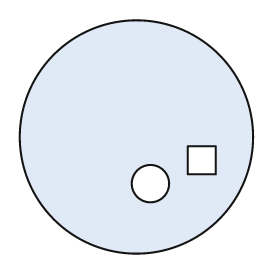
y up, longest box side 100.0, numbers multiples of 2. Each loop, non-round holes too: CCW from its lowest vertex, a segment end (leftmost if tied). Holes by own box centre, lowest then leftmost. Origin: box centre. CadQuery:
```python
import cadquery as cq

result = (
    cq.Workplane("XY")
    .moveTo(0.0, 0.0)
    .circle(50.0)
    .moveTo(6.0, -20.0)
    .circle(8.0)
    .moveTo(22.0, -16.0)
    .lineTo(34.0, -16.0)
    .lineTo(34.0, -4.0)
    .lineTo(22.0, -4.0)
    .close()
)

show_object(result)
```